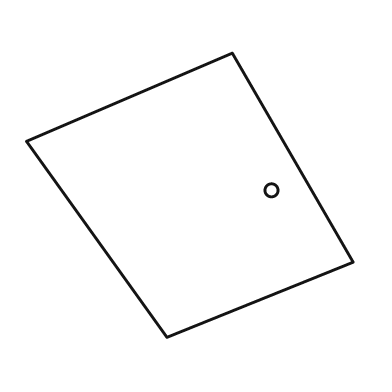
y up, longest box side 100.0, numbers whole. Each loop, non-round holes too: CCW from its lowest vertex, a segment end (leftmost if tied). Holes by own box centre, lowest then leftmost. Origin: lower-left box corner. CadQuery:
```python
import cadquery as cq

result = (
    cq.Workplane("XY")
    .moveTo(43.0, 0.0)
    .lineTo(100.0, 23.0)
    .lineTo(63.0, 87.0)
    .lineTo(0.0, 60.0)
    .close()
    .moveTo(75.0, 45.0)
    .circle(2.0)
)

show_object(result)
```